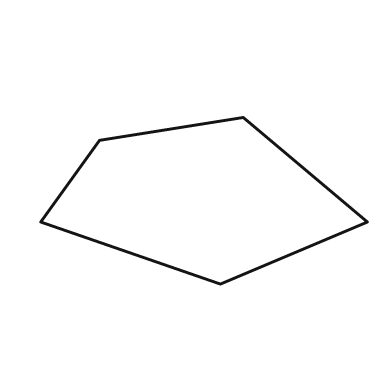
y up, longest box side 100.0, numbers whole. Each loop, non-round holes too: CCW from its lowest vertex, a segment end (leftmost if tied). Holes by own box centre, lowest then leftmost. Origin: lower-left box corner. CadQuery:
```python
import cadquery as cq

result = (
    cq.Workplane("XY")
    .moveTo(55.0, 0.0)
    .lineTo(100.0, 19.0)
    .lineTo(62.0, 51.0)
    .lineTo(18.0, 44.0)
    .lineTo(0.0, 19.0)
    .close()
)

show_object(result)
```